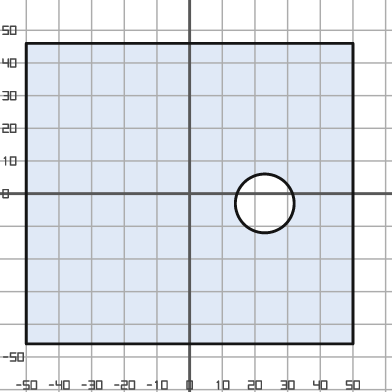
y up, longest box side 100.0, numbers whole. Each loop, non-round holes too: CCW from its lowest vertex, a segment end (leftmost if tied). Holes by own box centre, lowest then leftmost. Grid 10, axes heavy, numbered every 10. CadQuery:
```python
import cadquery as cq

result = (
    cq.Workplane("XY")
    .moveTo(-50.0, -46.0)
    .lineTo(50.0, -46.0)
    .lineTo(50.0, 46.0)
    .lineTo(-50.0, 46.0)
    .close()
    .moveTo(23.0, -3.0)
    .circle(9.0)
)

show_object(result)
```